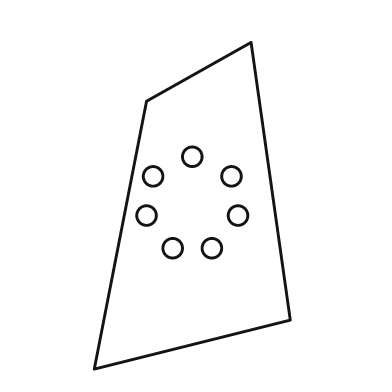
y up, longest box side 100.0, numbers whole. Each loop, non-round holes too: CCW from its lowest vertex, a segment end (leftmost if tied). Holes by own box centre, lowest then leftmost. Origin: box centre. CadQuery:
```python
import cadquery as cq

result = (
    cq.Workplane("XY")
    .moveTo(-30.0, -50.0)
    .lineTo(30.0, -35.0)
    .lineTo(18.0, 50.0)
    .lineTo(-14.0, 32.0)
    .close()
    .moveTo(-6.0, -13.0)
    .circle(3.0)
    .moveTo(6.0, -13.0)
    .circle(3.0)
    .moveTo(-14.0, -3.0)
    .circle(3.0)
    .moveTo(14.0, -3.0)
    .circle(3.0)
    .moveTo(-12.0, 9.0)
    .circle(3.0)
    .moveTo(12.0, 9.0)
    .circle(3.0)
    .moveTo(0.0, 15.0)
    .circle(3.0)
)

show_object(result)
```